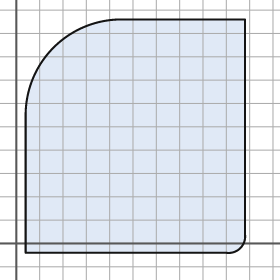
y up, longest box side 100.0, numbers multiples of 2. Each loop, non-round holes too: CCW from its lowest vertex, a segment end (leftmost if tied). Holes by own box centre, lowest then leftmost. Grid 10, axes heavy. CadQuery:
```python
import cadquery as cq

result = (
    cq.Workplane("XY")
    .moveTo(4.0, -4.0)
    .lineTo(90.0, -4.0)
    .threePointArc((96.0, -2.0), (98.0, 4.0))
    .lineTo(98.0, 96.0)
    .lineTo(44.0, 96.0)
    .threePointArc((16.0, 84.0), (4.0, 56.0))
    .close()
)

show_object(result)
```